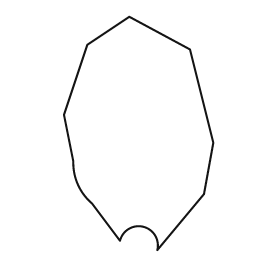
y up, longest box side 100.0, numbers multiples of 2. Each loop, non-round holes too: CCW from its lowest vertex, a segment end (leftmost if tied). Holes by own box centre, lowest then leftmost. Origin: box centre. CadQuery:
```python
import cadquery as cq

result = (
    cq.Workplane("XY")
    .moveTo(8.0, -50.0)
    .lineTo(28.0, -26.0)
    .lineTo(32.0, -4.0)
    .lineTo(22.0, 36.0)
    .lineTo(-4.0, 50.0)
    .lineTo(-22.0, 38.0)
    .lineTo(-32.0, 8.0)
    .lineTo(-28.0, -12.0)
    .threePointArc((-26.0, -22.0), (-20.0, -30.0))
    .lineTo(-8.0, -46.0)
    .threePointArc((2.0, -40.0), (8.0, -50.0))
    .close()
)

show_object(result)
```